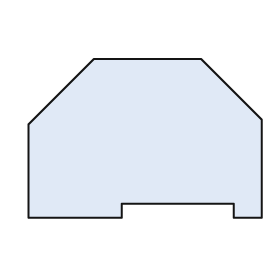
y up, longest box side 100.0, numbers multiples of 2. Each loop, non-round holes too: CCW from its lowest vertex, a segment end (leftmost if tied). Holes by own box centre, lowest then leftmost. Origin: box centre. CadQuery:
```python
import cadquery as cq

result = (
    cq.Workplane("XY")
    .moveTo(-50.0, -34.0)
    .lineTo(-10.0, -34.0)
    .lineTo(-10.0, -28.0)
    .lineTo(38.0, -28.0)
    .lineTo(38.0, -34.0)
    .lineTo(50.0, -34.0)
    .lineTo(50.0, 8.0)
    .lineTo(24.0, 34.0)
    .lineTo(-22.0, 34.0)
    .lineTo(-50.0, 6.0)
    .close()
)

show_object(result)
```